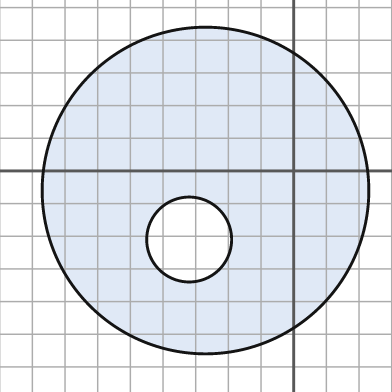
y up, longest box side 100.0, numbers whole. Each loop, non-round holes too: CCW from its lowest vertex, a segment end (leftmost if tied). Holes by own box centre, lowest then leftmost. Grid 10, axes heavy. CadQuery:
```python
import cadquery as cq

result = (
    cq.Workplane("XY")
    .moveTo(-27.0, -6.0)
    .circle(50.0)
    .moveTo(-32.0, -21.0)
    .circle(13.0)
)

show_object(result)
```